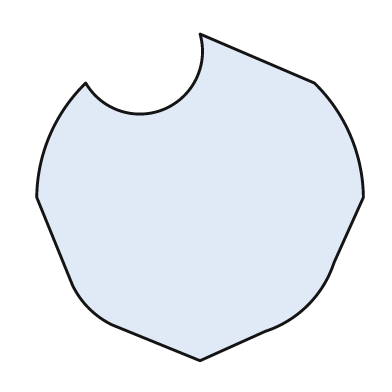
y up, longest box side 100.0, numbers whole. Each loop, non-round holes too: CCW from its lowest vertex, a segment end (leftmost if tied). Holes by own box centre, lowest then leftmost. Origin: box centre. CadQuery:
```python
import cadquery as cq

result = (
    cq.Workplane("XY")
    .moveTo(0.0, -50.0)
    .lineTo(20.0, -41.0)
    .threePointArc((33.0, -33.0), (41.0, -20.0))
    .lineTo(50.0, 0.0)
    .threePointArc((46.0, 19.0), (35.0, 35.0))
    .lineTo(0.0, 50.0)
    .threePointArc((-11.0, 27.0), (-35.0, 35.0))
    .threePointArc((-46.0, 19.0), (-50.0, 0.0))
    .lineTo(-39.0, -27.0)
    .threePointArc((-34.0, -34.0), (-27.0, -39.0))
    .close()
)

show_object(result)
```